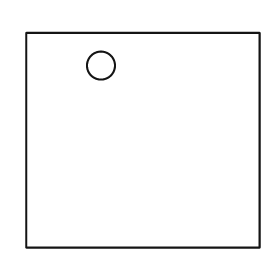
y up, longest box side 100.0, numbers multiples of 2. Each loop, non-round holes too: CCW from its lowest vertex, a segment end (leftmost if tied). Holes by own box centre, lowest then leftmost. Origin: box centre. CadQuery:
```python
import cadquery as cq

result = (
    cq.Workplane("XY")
    .moveTo(-50.0, -46.0)
    .lineTo(50.0, -46.0)
    .lineTo(50.0, 46.0)
    .lineTo(-50.0, 46.0)
    .close()
    .moveTo(-18.0, 32.0)
    .circle(6.0)
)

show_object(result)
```